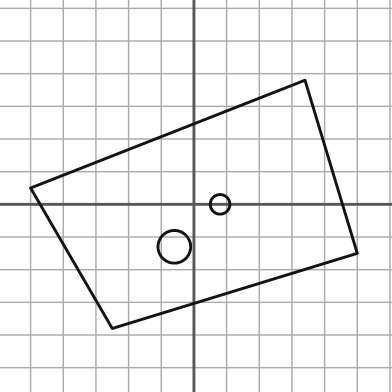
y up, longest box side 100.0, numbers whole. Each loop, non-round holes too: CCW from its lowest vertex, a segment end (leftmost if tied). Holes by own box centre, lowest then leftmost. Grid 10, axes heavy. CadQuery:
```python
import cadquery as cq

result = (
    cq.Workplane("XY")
    .moveTo(-25.0, -38.0)
    .lineTo(50.0, -15.0)
    .lineTo(34.0, 38.0)
    .lineTo(-50.0, 5.0)
    .close()
    .moveTo(-6.0, -13.0)
    .circle(5.0)
    .moveTo(8.0, 0.0)
    .circle(3.0)
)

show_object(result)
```